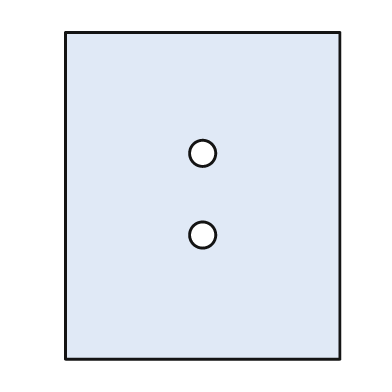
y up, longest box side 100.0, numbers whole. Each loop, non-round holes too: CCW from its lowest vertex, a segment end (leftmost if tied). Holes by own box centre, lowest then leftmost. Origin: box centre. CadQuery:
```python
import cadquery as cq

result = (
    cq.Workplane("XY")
    .moveTo(-42.0, -50.0)
    .lineTo(42.0, -50.0)
    .lineTo(42.0, 50.0)
    .lineTo(-42.0, 50.0)
    .close()
    .moveTo(0.0, -12.0)
    .circle(4.0)
    .moveTo(0.0, 13.0)
    .circle(4.0)
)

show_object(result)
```